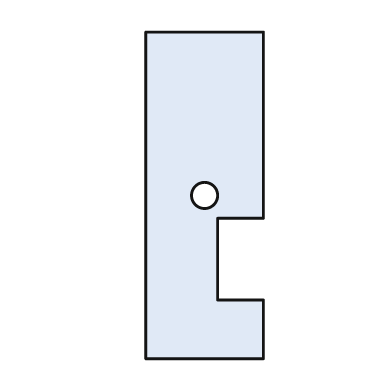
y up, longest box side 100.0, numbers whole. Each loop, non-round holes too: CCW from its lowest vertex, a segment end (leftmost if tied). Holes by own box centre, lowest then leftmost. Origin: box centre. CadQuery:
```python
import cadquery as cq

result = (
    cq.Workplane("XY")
    .moveTo(-18.0, -50.0)
    .lineTo(18.0, -50.0)
    .lineTo(18.0, -32.0)
    .lineTo(4.0, -32.0)
    .lineTo(4.0, -7.0)
    .lineTo(18.0, -7.0)
    .lineTo(18.0, 50.0)
    .lineTo(-18.0, 50.0)
    .close()
    .moveTo(0.0, 0.0)
    .circle(4.0)
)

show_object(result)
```